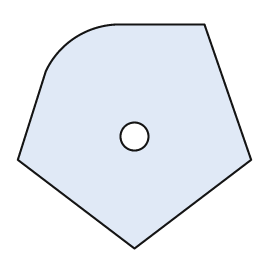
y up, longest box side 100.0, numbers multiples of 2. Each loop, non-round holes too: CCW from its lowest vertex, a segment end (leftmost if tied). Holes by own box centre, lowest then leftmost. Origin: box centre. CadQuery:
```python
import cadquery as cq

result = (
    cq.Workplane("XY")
    .moveTo(0.0, -48.0)
    .lineTo(50.0, -10.0)
    .lineTo(30.0, 48.0)
    .lineTo(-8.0, 48.0)
    .threePointArc((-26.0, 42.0), (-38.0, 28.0))
    .lineTo(-50.0, -10.0)
    .close()
    .moveTo(0.0, 0.0)
    .circle(6.0)
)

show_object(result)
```